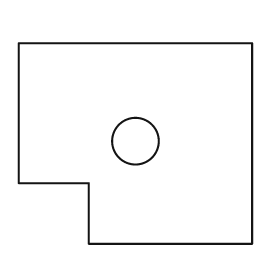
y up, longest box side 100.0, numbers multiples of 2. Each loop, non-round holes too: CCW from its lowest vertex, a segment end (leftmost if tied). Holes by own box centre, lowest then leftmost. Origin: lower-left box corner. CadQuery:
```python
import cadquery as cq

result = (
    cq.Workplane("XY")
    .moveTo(30.0, 0.0)
    .lineTo(100.0, 0.0)
    .lineTo(100.0, 86.0)
    .lineTo(0.0, 86.0)
    .lineTo(0.0, 26.0)
    .lineTo(30.0, 26.0)
    .close()
    .moveTo(50.0, 44.0)
    .circle(10.0)
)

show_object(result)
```